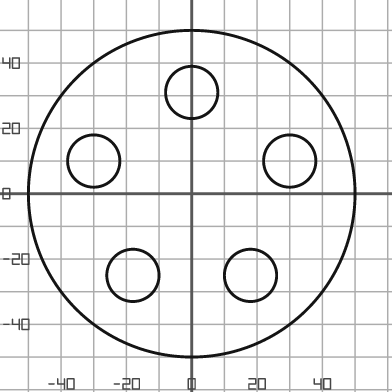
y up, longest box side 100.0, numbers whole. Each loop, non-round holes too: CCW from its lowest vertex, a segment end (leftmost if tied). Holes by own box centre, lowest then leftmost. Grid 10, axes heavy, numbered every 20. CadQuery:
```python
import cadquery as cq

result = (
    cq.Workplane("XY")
    .moveTo(0.0, 0.0)
    .circle(50.0)
    .moveTo(-18.0, -25.0)
    .circle(8.0)
    .moveTo(18.0, -25.0)
    .circle(8.0)
    .moveTo(-30.0, 10.0)
    .circle(8.0)
    .moveTo(30.0, 10.0)
    .circle(8.0)
    .moveTo(0.0, 31.0)
    .circle(8.0)
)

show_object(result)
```